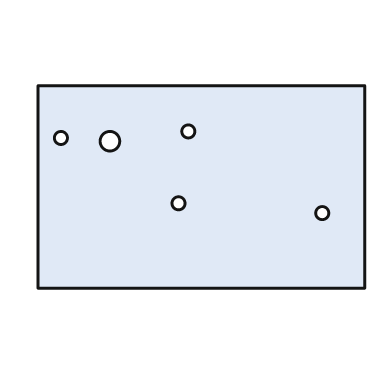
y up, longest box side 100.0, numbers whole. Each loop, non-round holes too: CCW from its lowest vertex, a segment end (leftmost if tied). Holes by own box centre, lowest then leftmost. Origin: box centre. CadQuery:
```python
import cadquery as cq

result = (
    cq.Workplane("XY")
    .moveTo(-50.0, -31.0)
    .lineTo(50.0, -31.0)
    .lineTo(50.0, 31.0)
    .lineTo(-50.0, 31.0)
    .close()
    .moveTo(37.0, -8.0)
    .circle(2.0)
    .moveTo(-7.0, -5.0)
    .circle(2.0)
    .moveTo(-28.0, 14.0)
    .circle(3.0)
    .moveTo(-43.0, 15.0)
    .circle(2.0)
    .moveTo(-4.0, 17.0)
    .circle(2.0)
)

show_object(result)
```